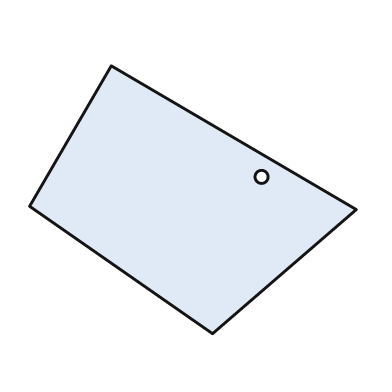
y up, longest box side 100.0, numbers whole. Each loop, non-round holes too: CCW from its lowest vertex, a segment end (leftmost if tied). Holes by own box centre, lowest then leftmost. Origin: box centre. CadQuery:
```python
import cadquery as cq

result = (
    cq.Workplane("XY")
    .moveTo(6.0, -41.0)
    .lineTo(50.0, -3.0)
    .lineTo(-25.0, 41.0)
    .lineTo(-50.0, -2.0)
    .close()
    .moveTo(21.0, 7.0)
    .circle(2.0)
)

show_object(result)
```